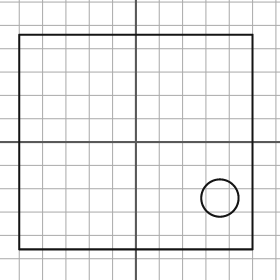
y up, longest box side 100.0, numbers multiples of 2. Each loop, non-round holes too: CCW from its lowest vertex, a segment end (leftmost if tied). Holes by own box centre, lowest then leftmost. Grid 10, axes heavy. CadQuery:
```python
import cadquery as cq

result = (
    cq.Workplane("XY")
    .moveTo(-50.0, -46.0)
    .lineTo(50.0, -46.0)
    .lineTo(50.0, 46.0)
    .lineTo(-50.0, 46.0)
    .close()
    .moveTo(36.0, -24.0)
    .circle(8.0)
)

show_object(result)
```